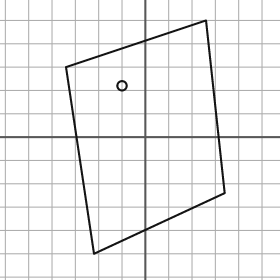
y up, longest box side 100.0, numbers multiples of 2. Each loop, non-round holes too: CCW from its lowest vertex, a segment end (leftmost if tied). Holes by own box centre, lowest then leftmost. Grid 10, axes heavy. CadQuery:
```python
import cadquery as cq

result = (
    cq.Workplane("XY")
    .moveTo(-22.0, -50.0)
    .lineTo(34.0, -24.0)
    .lineTo(26.0, 50.0)
    .lineTo(-34.0, 30.0)
    .close()
    .moveTo(-10.0, 22.0)
    .circle(2.0)
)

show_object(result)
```